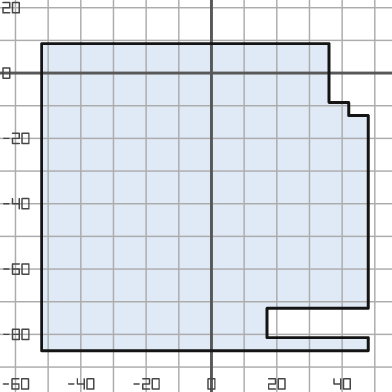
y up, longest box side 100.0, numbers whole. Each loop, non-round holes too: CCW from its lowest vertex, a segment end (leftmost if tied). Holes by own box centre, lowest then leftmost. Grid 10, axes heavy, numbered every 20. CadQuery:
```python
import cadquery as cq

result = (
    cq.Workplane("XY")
    .moveTo(-52.0, -85.0)
    .lineTo(48.0, -85.0)
    .lineTo(48.0, -81.0)
    .lineTo(17.0, -81.0)
    .lineTo(17.0, -72.0)
    .lineTo(48.0, -72.0)
    .lineTo(48.0, -13.0)
    .lineTo(42.0, -13.0)
    .lineTo(42.0, -9.0)
    .lineTo(36.0, -9.0)
    .lineTo(36.0, 9.0)
    .lineTo(-52.0, 9.0)
    .close()
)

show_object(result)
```